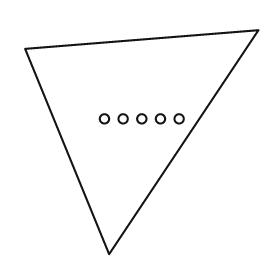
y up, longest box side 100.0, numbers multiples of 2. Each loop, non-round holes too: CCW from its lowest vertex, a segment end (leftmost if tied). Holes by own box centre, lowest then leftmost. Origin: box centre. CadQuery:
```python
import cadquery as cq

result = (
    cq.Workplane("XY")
    .moveTo(-14.0, -48.0)
    .lineTo(50.0, 48.0)
    .lineTo(-50.0, 40.0)
    .close()
    .moveTo(-16.0, 10.0)
    .circle(2.0)
    .moveTo(-8.0, 10.0)
    .circle(2.0)
    .moveTo(0.0, 10.0)
    .circle(2.0)
    .moveTo(8.0, 10.0)
    .circle(2.0)
    .moveTo(16.0, 10.0)
    .circle(2.0)
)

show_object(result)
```